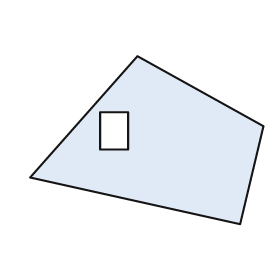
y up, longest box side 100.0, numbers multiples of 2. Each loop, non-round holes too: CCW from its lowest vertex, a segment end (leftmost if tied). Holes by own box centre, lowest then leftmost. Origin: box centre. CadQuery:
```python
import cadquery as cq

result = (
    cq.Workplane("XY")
    .moveTo(40.0, -36.0)
    .lineTo(50.0, 6.0)
    .lineTo(-4.0, 36.0)
    .lineTo(-50.0, -16.0)
    .close()
    .moveTo(-20.0, -4.0)
    .lineTo(-8.0, -4.0)
    .lineTo(-8.0, 12.0)
    .lineTo(-20.0, 12.0)
    .close()
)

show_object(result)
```